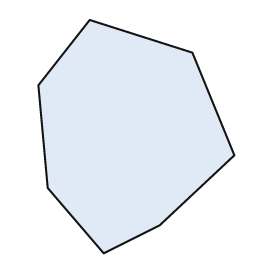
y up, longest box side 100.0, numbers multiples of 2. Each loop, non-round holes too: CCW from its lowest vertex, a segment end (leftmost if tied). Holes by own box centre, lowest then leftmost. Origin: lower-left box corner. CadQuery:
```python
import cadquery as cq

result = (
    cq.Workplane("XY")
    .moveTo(28.0, 0.0)
    .lineTo(52.0, 12.0)
    .lineTo(84.0, 42.0)
    .lineTo(66.0, 86.0)
    .lineTo(22.0, 100.0)
    .lineTo(0.0, 72.0)
    .lineTo(4.0, 28.0)
    .close()
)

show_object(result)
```